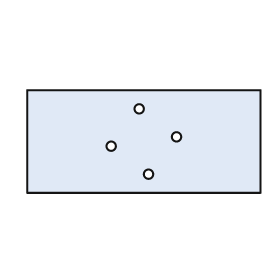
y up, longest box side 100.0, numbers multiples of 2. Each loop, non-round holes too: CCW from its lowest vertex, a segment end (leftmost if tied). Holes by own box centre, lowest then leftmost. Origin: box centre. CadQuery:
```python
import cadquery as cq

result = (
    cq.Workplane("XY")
    .moveTo(-50.0, -22.0)
    .lineTo(50.0, -22.0)
    .lineTo(50.0, 22.0)
    .lineTo(-50.0, 22.0)
    .close()
    .moveTo(2.0, -14.0)
    .circle(2.0)
    .moveTo(-14.0, -2.0)
    .circle(2.0)
    .moveTo(14.0, 2.0)
    .circle(2.0)
    .moveTo(-2.0, 14.0)
    .circle(2.0)
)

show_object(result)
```